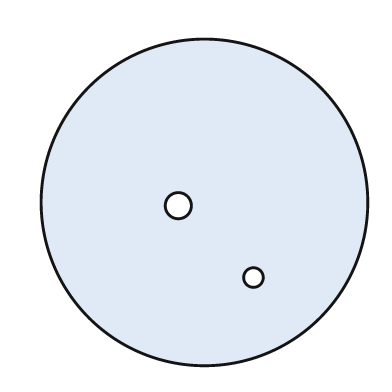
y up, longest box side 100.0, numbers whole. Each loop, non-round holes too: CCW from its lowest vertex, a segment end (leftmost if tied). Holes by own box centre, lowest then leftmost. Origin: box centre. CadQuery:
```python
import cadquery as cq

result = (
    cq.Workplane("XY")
    .moveTo(0.0, 0.0)
    .circle(50.0)
    .moveTo(15.0, -23.0)
    .circle(3.0)
    .moveTo(-8.0, -1.0)
    .circle(4.0)
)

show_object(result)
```